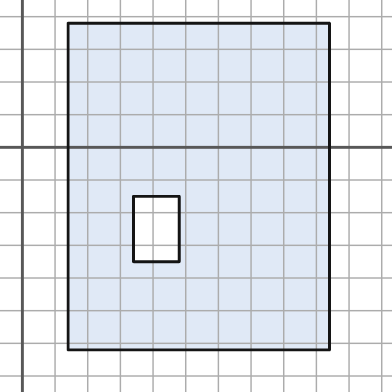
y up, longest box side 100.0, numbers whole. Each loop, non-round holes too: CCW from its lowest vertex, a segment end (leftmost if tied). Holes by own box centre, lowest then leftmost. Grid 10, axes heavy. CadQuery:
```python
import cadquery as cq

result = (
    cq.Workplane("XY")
    .moveTo(14.0, -62.0)
    .lineTo(94.0, -62.0)
    .lineTo(94.0, 38.0)
    .lineTo(14.0, 38.0)
    .close()
    .moveTo(34.0, -35.0)
    .lineTo(48.0, -35.0)
    .lineTo(48.0, -15.0)
    .lineTo(34.0, -15.0)
    .close()
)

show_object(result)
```